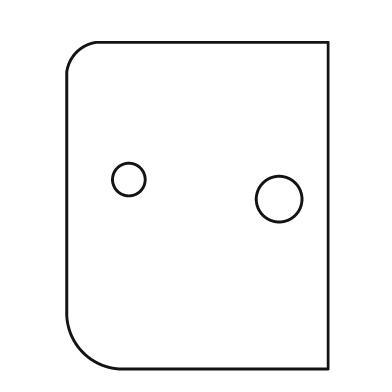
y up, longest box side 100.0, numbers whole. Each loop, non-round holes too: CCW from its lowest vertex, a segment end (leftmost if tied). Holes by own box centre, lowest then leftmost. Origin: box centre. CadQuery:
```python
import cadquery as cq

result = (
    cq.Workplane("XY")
    .moveTo(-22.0, -50.0)
    .lineTo(40.0, -50.0)
    .lineTo(40.0, 50.0)
    .lineTo(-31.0, 50.0)
    .threePointArc((-37.0, 47.0), (-40.0, 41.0))
    .lineTo(-40.0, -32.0)
    .threePointArc((-35.0, -45.0), (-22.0, -50.0))
    .close()
    .moveTo(25.0, 2.0)
    .circle(7.0)
    .moveTo(-21.0, 8.0)
    .circle(5.0)
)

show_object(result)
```